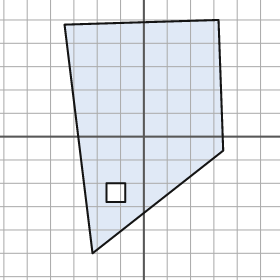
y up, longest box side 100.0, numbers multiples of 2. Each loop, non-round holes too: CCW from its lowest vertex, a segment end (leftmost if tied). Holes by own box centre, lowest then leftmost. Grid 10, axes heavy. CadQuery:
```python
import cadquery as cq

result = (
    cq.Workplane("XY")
    .moveTo(-22.0, -50.0)
    .lineTo(34.0, -6.0)
    .lineTo(32.0, 50.0)
    .lineTo(-34.0, 48.0)
    .close()
    .moveTo(-16.0, -28.0)
    .lineTo(-8.0, -28.0)
    .lineTo(-8.0, -20.0)
    .lineTo(-16.0, -20.0)
    .close()
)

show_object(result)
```